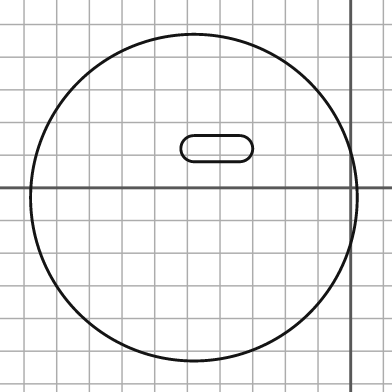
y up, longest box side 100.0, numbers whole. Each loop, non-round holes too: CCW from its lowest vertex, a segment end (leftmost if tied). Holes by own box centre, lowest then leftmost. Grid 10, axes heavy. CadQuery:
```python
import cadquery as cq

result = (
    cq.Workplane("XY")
    .moveTo(-48.0, -3.0)
    .circle(50.0)
    .moveTo(-48.0, 8.0)
    .lineTo(-34.0, 8.0)
    .threePointArc((-30.0, 12.0), (-34.0, 16.0))
    .lineTo(-48.0, 16.0)
    .threePointArc((-52.0, 12.0), (-48.0, 8.0))
    .close()
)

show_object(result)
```